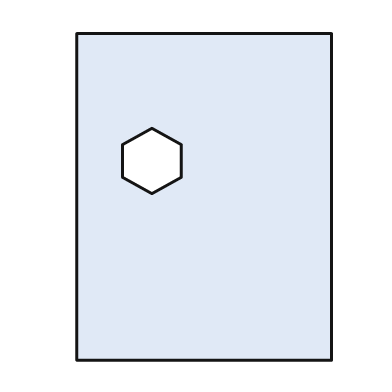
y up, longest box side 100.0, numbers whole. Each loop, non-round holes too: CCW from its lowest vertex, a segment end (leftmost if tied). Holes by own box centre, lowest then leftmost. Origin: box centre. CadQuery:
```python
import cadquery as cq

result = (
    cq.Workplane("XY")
    .moveTo(-39.0, -50.0)
    .lineTo(39.0, -50.0)
    .lineTo(39.0, 50.0)
    .lineTo(-39.0, 50.0)
    .close()
    .moveTo(-16.0, 1.0)
    .lineTo(-7.0, 6.0)
    .lineTo(-7.0, 16.0)
    .lineTo(-16.0, 21.0)
    .lineTo(-25.0, 16.0)
    .lineTo(-25.0, 6.0)
    .close()
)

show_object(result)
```